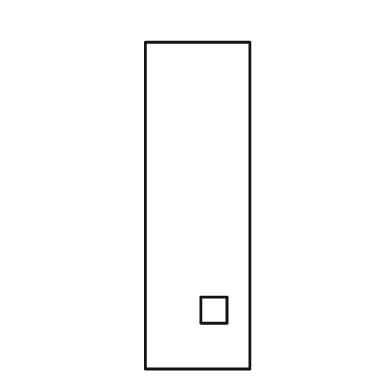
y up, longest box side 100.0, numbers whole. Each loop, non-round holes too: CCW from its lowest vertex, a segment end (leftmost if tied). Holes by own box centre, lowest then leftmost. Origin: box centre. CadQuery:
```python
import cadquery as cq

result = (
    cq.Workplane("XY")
    .moveTo(-16.0, -50.0)
    .lineTo(16.0, -50.0)
    .lineTo(16.0, 50.0)
    .lineTo(-16.0, 50.0)
    .close()
    .moveTo(1.0, -36.0)
    .lineTo(9.0, -36.0)
    .lineTo(9.0, -28.0)
    .lineTo(1.0, -28.0)
    .close()
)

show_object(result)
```